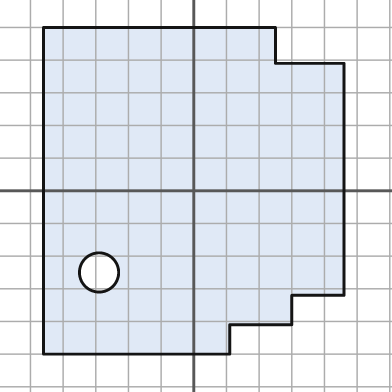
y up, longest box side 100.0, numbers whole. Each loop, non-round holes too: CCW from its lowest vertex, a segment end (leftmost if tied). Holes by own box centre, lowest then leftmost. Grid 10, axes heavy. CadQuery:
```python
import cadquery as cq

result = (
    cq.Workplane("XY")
    .moveTo(-46.0, -50.0)
    .lineTo(11.0, -50.0)
    .lineTo(11.0, -41.0)
    .lineTo(30.0, -41.0)
    .lineTo(30.0, -32.0)
    .lineTo(46.0, -32.0)
    .lineTo(46.0, 39.0)
    .lineTo(25.0, 39.0)
    .lineTo(25.0, 50.0)
    .lineTo(-46.0, 50.0)
    .close()
    .moveTo(-29.0, -25.0)
    .circle(6.0)
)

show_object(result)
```